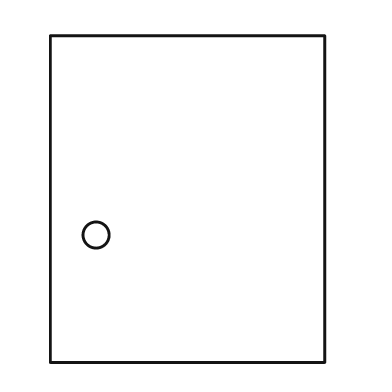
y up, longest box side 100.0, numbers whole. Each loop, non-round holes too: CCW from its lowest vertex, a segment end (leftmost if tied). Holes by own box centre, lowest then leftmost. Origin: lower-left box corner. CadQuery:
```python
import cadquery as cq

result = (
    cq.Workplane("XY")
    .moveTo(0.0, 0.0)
    .lineTo(84.0, 0.0)
    .lineTo(84.0, 100.0)
    .lineTo(0.0, 100.0)
    .close()
    .moveTo(14.0, 39.0)
    .circle(4.0)
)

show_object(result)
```